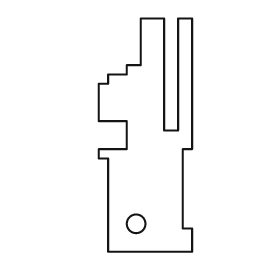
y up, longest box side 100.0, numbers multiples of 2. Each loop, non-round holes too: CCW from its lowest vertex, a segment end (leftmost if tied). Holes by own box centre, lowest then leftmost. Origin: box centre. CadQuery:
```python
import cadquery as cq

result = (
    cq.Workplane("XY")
    .moveTo(-16.0, -50.0)
    .lineTo(20.0, -50.0)
    .lineTo(20.0, -40.0)
    .lineTo(16.0, -40.0)
    .lineTo(16.0, -6.0)
    .lineTo(20.0, -6.0)
    .lineTo(20.0, 50.0)
    .lineTo(14.0, 50.0)
    .lineTo(14.0, 2.0)
    .lineTo(8.0, 2.0)
    .lineTo(8.0, 50.0)
    .lineTo(-2.0, 50.0)
    .lineTo(-2.0, 30.0)
    .lineTo(-8.0, 30.0)
    .lineTo(-8.0, 26.0)
    .lineTo(-16.0, 26.0)
    .lineTo(-16.0, 22.0)
    .lineTo(-20.0, 22.0)
    .lineTo(-20.0, 6.0)
    .lineTo(-8.0, 6.0)
    .lineTo(-8.0, -6.0)
    .lineTo(-20.0, -6.0)
    .lineTo(-20.0, -10.0)
    .lineTo(-16.0, -10.0)
    .close()
    .moveTo(-4.0, -38.0)
    .circle(4.0)
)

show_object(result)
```